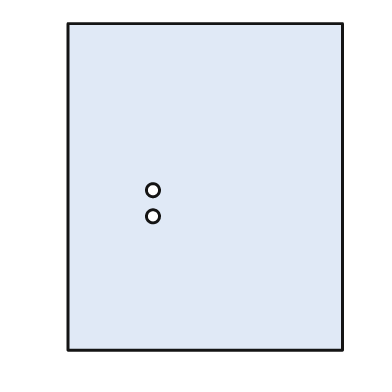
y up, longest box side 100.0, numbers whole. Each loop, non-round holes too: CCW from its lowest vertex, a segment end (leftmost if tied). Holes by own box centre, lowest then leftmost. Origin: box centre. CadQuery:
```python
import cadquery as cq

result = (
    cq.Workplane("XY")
    .moveTo(-42.0, -50.0)
    .lineTo(42.0, -50.0)
    .lineTo(42.0, 50.0)
    .lineTo(-42.0, 50.0)
    .close()
    .moveTo(-16.0, -9.0)
    .circle(2.0)
    .moveTo(-16.0, -1.0)
    .circle(2.0)
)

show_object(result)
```